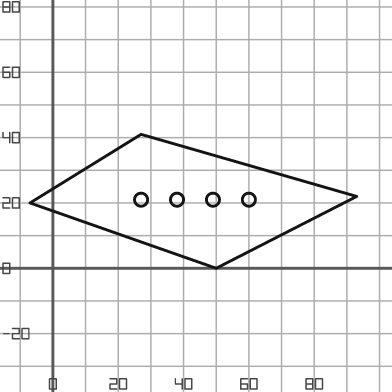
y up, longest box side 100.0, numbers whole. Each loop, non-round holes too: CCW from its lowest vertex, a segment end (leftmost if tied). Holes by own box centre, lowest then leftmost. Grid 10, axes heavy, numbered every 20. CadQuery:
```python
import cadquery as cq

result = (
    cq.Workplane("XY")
    .moveTo(50.0, 0.0)
    .lineTo(93.0, 22.0)
    .lineTo(27.0, 41.0)
    .lineTo(-7.0, 20.0)
    .close()
    .moveTo(27.0, 21.0)
    .circle(2.0)
    .moveTo(38.0, 21.0)
    .circle(2.0)
    .moveTo(49.0, 21.0)
    .circle(2.0)
    .moveTo(60.0, 21.0)
    .circle(2.0)
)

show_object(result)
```